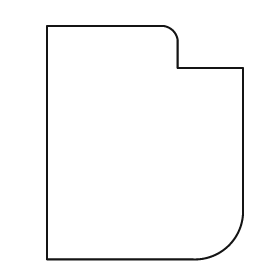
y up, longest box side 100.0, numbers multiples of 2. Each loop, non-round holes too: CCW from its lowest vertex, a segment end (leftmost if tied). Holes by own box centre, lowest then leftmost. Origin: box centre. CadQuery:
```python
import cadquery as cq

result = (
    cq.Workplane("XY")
    .moveTo(-42.0, -50.0)
    .lineTo(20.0, -50.0)
    .threePointArc((36.0, -44.0), (42.0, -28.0))
    .lineTo(42.0, 32.0)
    .lineTo(14.0, 32.0)
    .lineTo(14.0, 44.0)
    .threePointArc((12.0, 48.0), (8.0, 50.0))
    .lineTo(-42.0, 50.0)
    .close()
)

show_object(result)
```